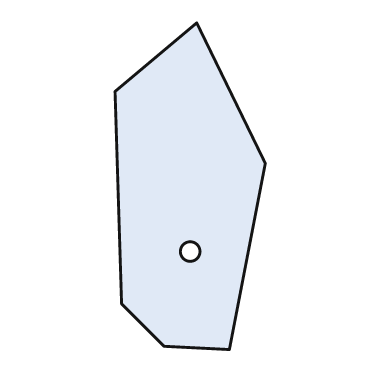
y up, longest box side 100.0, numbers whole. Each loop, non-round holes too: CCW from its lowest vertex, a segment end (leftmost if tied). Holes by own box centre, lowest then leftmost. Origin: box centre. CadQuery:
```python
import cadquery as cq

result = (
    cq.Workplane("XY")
    .moveTo(12.0, -50.0)
    .lineTo(23.0, 7.0)
    .lineTo(2.0, 50.0)
    .lineTo(-23.0, 29.0)
    .lineTo(-21.0, -36.0)
    .lineTo(-8.0, -49.0)
    .close()
    .moveTo(0.0, -20.0)
    .circle(3.0)
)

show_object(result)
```